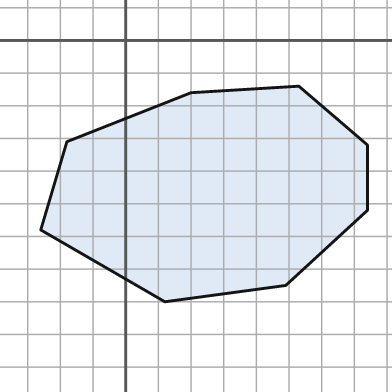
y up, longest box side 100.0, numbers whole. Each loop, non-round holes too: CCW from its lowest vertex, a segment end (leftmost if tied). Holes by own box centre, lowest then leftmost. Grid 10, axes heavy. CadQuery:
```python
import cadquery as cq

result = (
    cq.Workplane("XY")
    .moveTo(12.0, -80.0)
    .lineTo(49.0, -75.0)
    .lineTo(74.0, -52.0)
    .lineTo(74.0, -32.0)
    .lineTo(53.0, -14.0)
    .lineTo(20.0, -16.0)
    .lineTo(-18.0, -31.0)
    .lineTo(-26.0, -58.0)
    .close()
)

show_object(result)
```